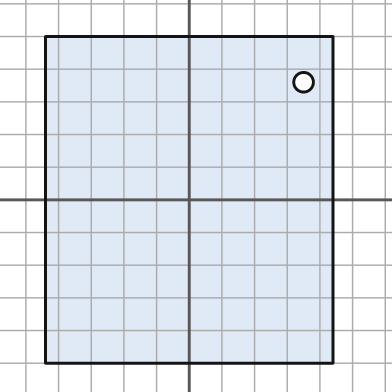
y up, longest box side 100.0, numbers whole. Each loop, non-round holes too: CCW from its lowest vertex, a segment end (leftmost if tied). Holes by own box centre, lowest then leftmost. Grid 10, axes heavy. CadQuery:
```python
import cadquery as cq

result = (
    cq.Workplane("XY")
    .moveTo(-44.0, -50.0)
    .lineTo(44.0, -50.0)
    .lineTo(44.0, 50.0)
    .lineTo(-44.0, 50.0)
    .close()
    .moveTo(35.0, 36.0)
    .circle(3.0)
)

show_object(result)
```